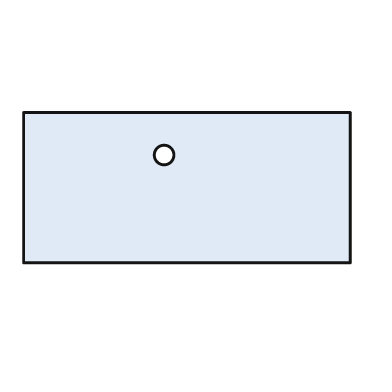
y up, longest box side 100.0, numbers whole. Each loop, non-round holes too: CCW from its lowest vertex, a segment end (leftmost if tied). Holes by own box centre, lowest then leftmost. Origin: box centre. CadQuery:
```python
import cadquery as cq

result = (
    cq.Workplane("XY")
    .moveTo(-50.0, -23.0)
    .lineTo(50.0, -23.0)
    .lineTo(50.0, 23.0)
    .lineTo(-50.0, 23.0)
    .close()
    .moveTo(-7.0, 10.0)
    .circle(3.0)
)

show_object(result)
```